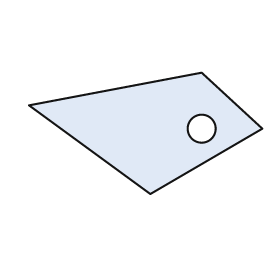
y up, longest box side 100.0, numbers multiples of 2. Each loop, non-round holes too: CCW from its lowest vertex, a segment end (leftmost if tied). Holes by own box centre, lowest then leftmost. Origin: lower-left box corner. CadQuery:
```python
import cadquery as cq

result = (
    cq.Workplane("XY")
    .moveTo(52.0, 0.0)
    .lineTo(100.0, 28.0)
    .lineTo(74.0, 52.0)
    .lineTo(0.0, 38.0)
    .close()
    .moveTo(74.0, 28.0)
    .circle(6.0)
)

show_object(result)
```